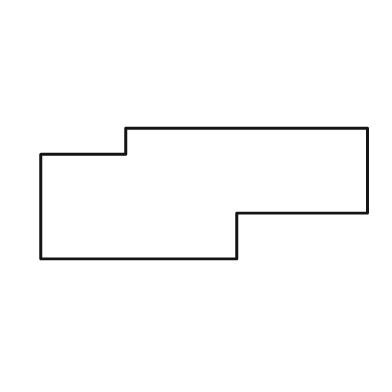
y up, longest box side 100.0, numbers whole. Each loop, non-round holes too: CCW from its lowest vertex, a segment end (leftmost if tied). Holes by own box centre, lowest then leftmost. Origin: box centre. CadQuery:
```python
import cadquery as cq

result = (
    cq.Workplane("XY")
    .moveTo(-50.0, -20.0)
    .lineTo(10.0, -20.0)
    .lineTo(10.0, -6.0)
    .lineTo(50.0, -6.0)
    .lineTo(50.0, 20.0)
    .lineTo(-24.0, 20.0)
    .lineTo(-24.0, 12.0)
    .lineTo(-50.0, 12.0)
    .close()
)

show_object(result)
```